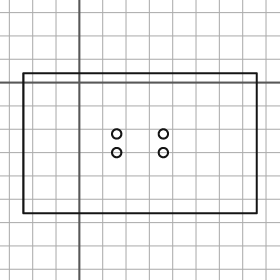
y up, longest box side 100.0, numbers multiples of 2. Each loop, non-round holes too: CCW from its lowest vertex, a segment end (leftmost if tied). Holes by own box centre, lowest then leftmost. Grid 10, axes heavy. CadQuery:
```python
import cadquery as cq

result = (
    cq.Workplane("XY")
    .moveTo(-24.0, -56.0)
    .lineTo(76.0, -56.0)
    .lineTo(76.0, 4.0)
    .lineTo(-24.0, 4.0)
    .close()
    .moveTo(16.0, -30.0)
    .circle(2.0)
    .moveTo(36.0, -30.0)
    .circle(2.0)
    .moveTo(16.0, -22.0)
    .circle(2.0)
    .moveTo(36.0, -22.0)
    .circle(2.0)
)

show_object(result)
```